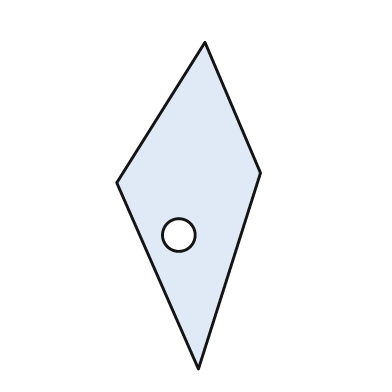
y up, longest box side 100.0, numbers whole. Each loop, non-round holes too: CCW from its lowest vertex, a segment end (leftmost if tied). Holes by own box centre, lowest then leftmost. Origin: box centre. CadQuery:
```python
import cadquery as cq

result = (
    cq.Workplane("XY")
    .moveTo(3.0, -50.0)
    .lineTo(22.0, 10.0)
    .lineTo(5.0, 50.0)
    .lineTo(-22.0, 7.0)
    .close()
    .moveTo(-3.0, -9.0)
    .circle(5.0)
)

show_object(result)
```